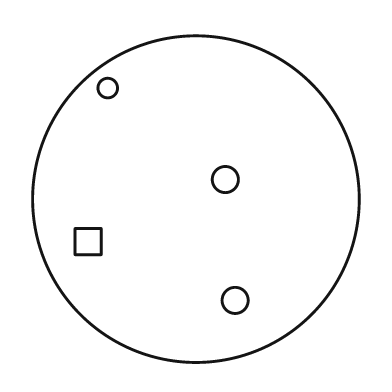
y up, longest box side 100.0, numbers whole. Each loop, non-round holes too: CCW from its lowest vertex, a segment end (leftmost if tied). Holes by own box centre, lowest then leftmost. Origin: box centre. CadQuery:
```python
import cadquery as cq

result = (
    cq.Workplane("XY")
    .moveTo(0.0, 0.0)
    .circle(50.0)
    .moveTo(12.0, -31.0)
    .circle(4.0)
    .moveTo(-37.0, -17.0)
    .lineTo(-29.0, -17.0)
    .lineTo(-29.0, -9.0)
    .lineTo(-37.0, -9.0)
    .close()
    .moveTo(9.0, 6.0)
    .circle(4.0)
    .moveTo(-27.0, 34.0)
    .circle(3.0)
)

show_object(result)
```